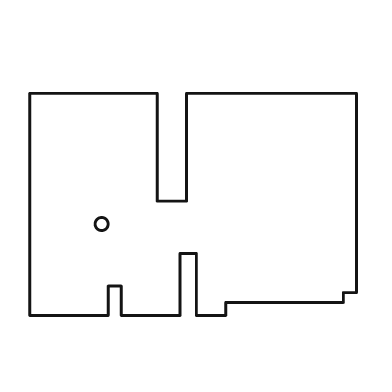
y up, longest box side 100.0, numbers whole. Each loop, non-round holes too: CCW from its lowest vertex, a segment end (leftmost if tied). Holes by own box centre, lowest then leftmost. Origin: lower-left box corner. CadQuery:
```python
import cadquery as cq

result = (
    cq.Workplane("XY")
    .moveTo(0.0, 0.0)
    .lineTo(24.0, 0.0)
    .lineTo(24.0, 9.0)
    .lineTo(28.0, 9.0)
    .lineTo(28.0, 0.0)
    .lineTo(46.0, 0.0)
    .lineTo(46.0, 19.0)
    .lineTo(51.0, 19.0)
    .lineTo(51.0, 0.0)
    .lineTo(60.0, 0.0)
    .lineTo(60.0, 4.0)
    .lineTo(96.0, 4.0)
    .lineTo(96.0, 7.0)
    .lineTo(100.0, 7.0)
    .lineTo(100.0, 68.0)
    .lineTo(48.0, 68.0)
    .lineTo(48.0, 35.0)
    .lineTo(39.0, 35.0)
    .lineTo(39.0, 68.0)
    .lineTo(0.0, 68.0)
    .close()
    .moveTo(22.0, 28.0)
    .circle(2.0)
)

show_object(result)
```